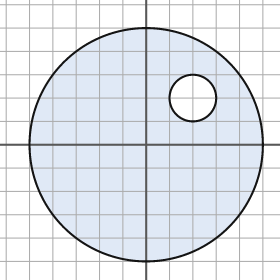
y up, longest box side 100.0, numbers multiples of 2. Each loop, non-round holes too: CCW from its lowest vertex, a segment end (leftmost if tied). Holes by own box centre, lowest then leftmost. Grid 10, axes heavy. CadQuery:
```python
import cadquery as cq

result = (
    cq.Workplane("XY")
    .moveTo(0.0, 0.0)
    .circle(50.0)
    .moveTo(20.0, 20.0)
    .circle(10.0)
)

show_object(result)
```